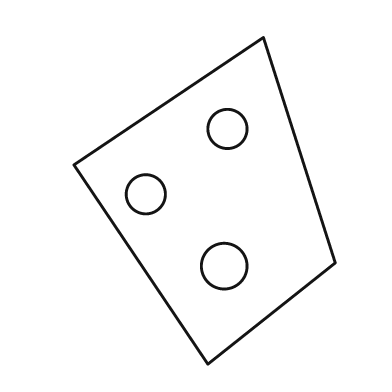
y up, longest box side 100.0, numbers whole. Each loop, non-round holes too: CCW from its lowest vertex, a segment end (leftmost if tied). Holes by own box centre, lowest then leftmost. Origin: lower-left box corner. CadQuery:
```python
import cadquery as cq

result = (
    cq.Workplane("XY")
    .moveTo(41.0, 0.0)
    .lineTo(80.0, 31.0)
    .lineTo(58.0, 100.0)
    .lineTo(0.0, 61.0)
    .close()
    .moveTo(46.0, 30.0)
    .circle(7.0)
    .moveTo(22.0, 52.0)
    .circle(6.0)
    .moveTo(47.0, 72.0)
    .circle(6.0)
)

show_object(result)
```